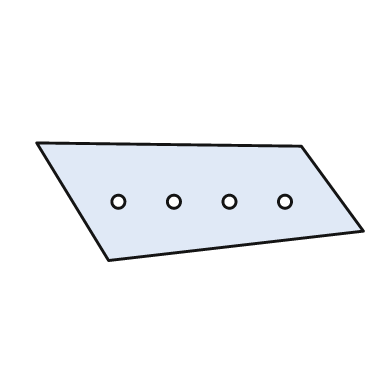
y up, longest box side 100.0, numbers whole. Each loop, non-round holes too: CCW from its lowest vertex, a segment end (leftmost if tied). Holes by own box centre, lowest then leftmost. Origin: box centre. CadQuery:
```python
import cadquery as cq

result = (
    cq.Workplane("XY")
    .moveTo(-28.0, -18.0)
    .lineTo(50.0, -9.0)
    .lineTo(31.0, 17.0)
    .lineTo(-50.0, 18.0)
    .close()
    .moveTo(-25.0, 0.0)
    .circle(2.0)
    .moveTo(-8.0, 0.0)
    .circle(2.0)
    .moveTo(9.0, 0.0)
    .circle(2.0)
    .moveTo(26.0, 0.0)
    .circle(2.0)
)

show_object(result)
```